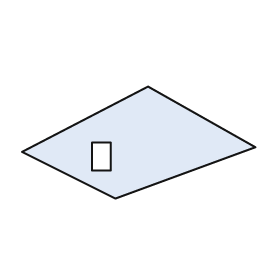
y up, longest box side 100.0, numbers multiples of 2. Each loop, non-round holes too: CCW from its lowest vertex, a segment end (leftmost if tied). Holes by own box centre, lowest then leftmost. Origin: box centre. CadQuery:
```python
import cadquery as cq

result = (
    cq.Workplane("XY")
    .moveTo(-10.0, -24.0)
    .lineTo(50.0, -2.0)
    .lineTo(4.0, 24.0)
    .lineTo(-50.0, -4.0)
    .close()
    .moveTo(-20.0, -12.0)
    .lineTo(-12.0, -12.0)
    .lineTo(-12.0, 0.0)
    .lineTo(-20.0, 0.0)
    .close()
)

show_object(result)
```